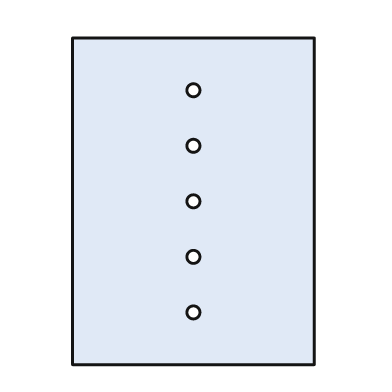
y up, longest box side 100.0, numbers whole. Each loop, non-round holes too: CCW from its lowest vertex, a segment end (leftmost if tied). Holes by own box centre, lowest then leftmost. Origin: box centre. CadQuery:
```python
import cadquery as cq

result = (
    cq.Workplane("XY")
    .moveTo(-37.0, -50.0)
    .lineTo(37.0, -50.0)
    .lineTo(37.0, 50.0)
    .lineTo(-37.0, 50.0)
    .close()
    .moveTo(0.0, -34.0)
    .circle(2.0)
    .moveTo(0.0, -17.0)
    .circle(2.0)
    .moveTo(0.0, 0.0)
    .circle(2.0)
    .moveTo(0.0, 17.0)
    .circle(2.0)
    .moveTo(0.0, 34.0)
    .circle(2.0)
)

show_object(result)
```